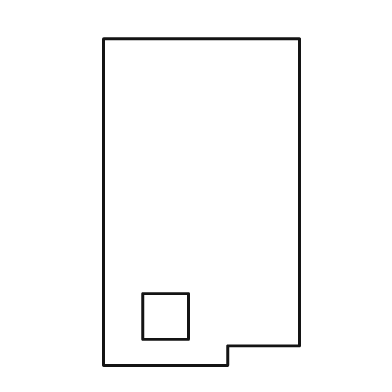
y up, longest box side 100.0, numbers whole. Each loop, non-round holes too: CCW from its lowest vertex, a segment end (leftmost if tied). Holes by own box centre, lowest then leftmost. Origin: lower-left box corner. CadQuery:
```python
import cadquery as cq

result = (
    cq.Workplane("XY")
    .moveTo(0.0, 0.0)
    .lineTo(38.0, 0.0)
    .lineTo(38.0, 6.0)
    .lineTo(60.0, 6.0)
    .lineTo(60.0, 100.0)
    .lineTo(0.0, 100.0)
    .close()
    .moveTo(12.0, 8.0)
    .lineTo(26.0, 8.0)
    .lineTo(26.0, 22.0)
    .lineTo(12.0, 22.0)
    .close()
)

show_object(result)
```